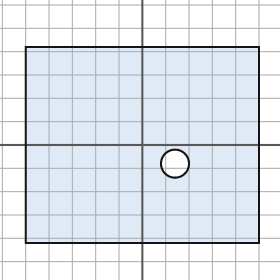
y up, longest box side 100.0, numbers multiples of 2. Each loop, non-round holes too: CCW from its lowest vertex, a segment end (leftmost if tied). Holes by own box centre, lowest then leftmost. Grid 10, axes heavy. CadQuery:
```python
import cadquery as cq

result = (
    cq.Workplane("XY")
    .moveTo(-50.0, -42.0)
    .lineTo(50.0, -42.0)
    .lineTo(50.0, 42.0)
    .lineTo(-50.0, 42.0)
    .close()
    .moveTo(14.0, -8.0)
    .circle(6.0)
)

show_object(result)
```